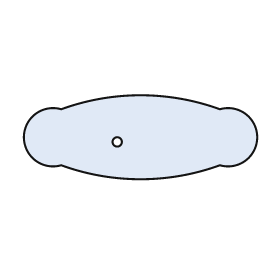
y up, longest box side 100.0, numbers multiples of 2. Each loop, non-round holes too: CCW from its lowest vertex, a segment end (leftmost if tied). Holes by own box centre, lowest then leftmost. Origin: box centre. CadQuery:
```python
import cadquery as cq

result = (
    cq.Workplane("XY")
    .moveTo(-34.0, -12.0)
    .threePointArc((0.0, -18.0), (34.0, -12.0))
    .threePointArc((50.0, 0.0), (34.0, 12.0))
    .threePointArc((0.0, 18.0), (-34.0, 12.0))
    .threePointArc((-50.0, 0.0), (-34.0, -12.0))
    .close()
    .moveTo(-10.0, -2.0)
    .circle(2.0)
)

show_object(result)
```